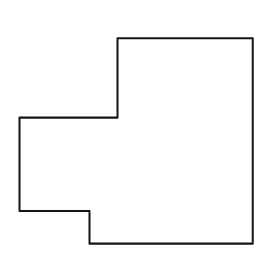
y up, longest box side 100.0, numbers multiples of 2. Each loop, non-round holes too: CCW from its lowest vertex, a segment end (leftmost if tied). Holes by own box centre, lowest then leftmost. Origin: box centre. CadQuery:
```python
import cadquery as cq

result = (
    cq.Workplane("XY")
    .moveTo(-20.0, -44.0)
    .lineTo(50.0, -44.0)
    .lineTo(50.0, 44.0)
    .lineTo(-8.0, 44.0)
    .lineTo(-8.0, 10.0)
    .lineTo(-50.0, 10.0)
    .lineTo(-50.0, -30.0)
    .lineTo(-20.0, -30.0)
    .close()
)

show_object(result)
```